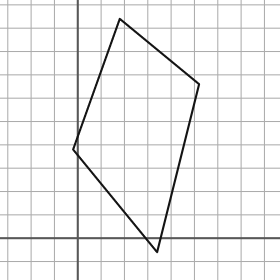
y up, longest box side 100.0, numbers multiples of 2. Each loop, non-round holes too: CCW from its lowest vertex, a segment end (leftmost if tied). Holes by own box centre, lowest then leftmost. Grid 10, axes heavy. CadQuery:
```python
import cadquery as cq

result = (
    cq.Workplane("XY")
    .moveTo(34.0, -6.0)
    .lineTo(52.0, 66.0)
    .lineTo(18.0, 94.0)
    .lineTo(-2.0, 38.0)
    .close()
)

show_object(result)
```